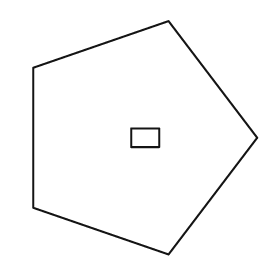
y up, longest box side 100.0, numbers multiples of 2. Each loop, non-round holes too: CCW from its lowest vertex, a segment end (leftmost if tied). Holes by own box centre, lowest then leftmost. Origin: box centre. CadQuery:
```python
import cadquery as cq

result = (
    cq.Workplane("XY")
    .moveTo(10.0, -50.0)
    .lineTo(48.0, 0.0)
    .lineTo(10.0, 50.0)
    .lineTo(-48.0, 30.0)
    .lineTo(-48.0, -30.0)
    .close()
    .moveTo(-6.0, -4.0)
    .lineTo(6.0, -4.0)
    .lineTo(6.0, 4.0)
    .lineTo(-6.0, 4.0)
    .close()
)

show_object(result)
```